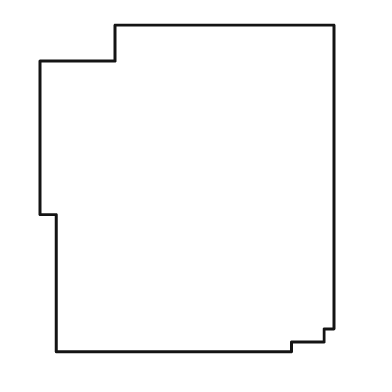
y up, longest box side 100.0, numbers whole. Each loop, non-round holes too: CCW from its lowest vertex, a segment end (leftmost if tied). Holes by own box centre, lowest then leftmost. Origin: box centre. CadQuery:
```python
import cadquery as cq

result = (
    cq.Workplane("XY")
    .moveTo(-40.0, -50.0)
    .lineTo(32.0, -50.0)
    .lineTo(32.0, -47.0)
    .lineTo(42.0, -47.0)
    .lineTo(42.0, -43.0)
    .lineTo(45.0, -43.0)
    .lineTo(45.0, 50.0)
    .lineTo(-22.0, 50.0)
    .lineTo(-22.0, 39.0)
    .lineTo(-45.0, 39.0)
    .lineTo(-45.0, -8.0)
    .lineTo(-40.0, -8.0)
    .close()
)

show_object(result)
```